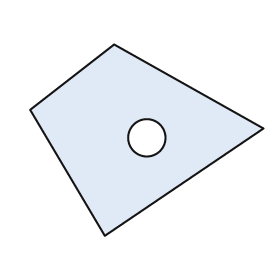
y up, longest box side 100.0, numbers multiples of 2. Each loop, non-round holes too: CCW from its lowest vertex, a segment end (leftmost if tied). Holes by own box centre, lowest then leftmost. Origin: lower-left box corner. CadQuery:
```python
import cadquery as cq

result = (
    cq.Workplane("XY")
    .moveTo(32.0, 0.0)
    .lineTo(100.0, 46.0)
    .lineTo(36.0, 82.0)
    .lineTo(0.0, 54.0)
    .close()
    .moveTo(50.0, 42.0)
    .circle(8.0)
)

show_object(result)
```